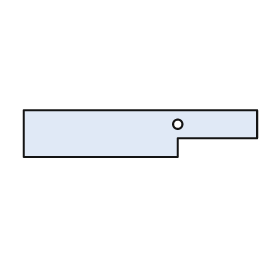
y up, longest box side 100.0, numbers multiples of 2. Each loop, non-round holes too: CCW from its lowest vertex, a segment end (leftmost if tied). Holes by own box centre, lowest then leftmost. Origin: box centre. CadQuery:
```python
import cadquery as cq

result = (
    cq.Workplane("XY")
    .moveTo(-50.0, -10.0)
    .lineTo(16.0, -10.0)
    .lineTo(16.0, -2.0)
    .lineTo(50.0, -2.0)
    .lineTo(50.0, 10.0)
    .lineTo(-50.0, 10.0)
    .close()
    .moveTo(16.0, 4.0)
    .circle(2.0)
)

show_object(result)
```